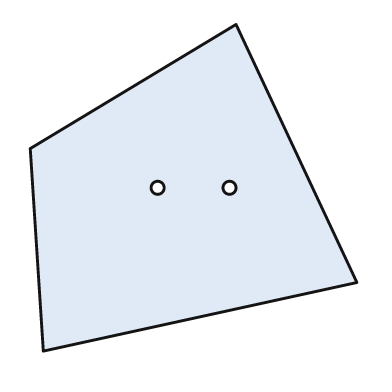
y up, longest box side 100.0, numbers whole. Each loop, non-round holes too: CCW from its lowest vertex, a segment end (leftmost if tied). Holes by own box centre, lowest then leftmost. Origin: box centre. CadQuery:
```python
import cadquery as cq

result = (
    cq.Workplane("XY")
    .moveTo(-46.0, -50.0)
    .lineTo(50.0, -29.0)
    .lineTo(13.0, 50.0)
    .lineTo(-50.0, 12.0)
    .close()
    .moveTo(-11.0, 0.0)
    .circle(2.0)
    .moveTo(11.0, 0.0)
    .circle(2.0)
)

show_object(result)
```